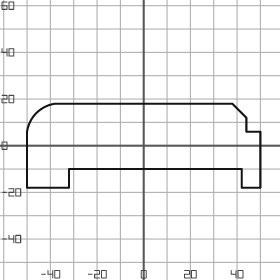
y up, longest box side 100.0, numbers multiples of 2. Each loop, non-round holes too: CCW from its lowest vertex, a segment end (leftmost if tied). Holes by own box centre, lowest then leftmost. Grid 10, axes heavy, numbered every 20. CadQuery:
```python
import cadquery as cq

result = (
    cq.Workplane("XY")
    .moveTo(-50.0, -18.0)
    .lineTo(-32.0, -18.0)
    .lineTo(-32.0, -10.0)
    .lineTo(42.0, -10.0)
    .lineTo(42.0, -18.0)
    .lineTo(50.0, -18.0)
    .lineTo(50.0, 6.0)
    .lineTo(44.0, 6.0)
    .lineTo(44.0, 12.0)
    .lineTo(38.0, 18.0)
    .lineTo(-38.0, 18.0)
    .threePointArc((-46.0, 14.0), (-50.0, 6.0))
    .close()
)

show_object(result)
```